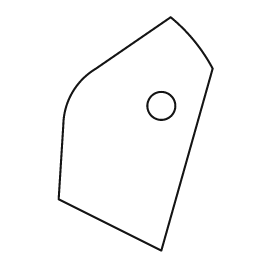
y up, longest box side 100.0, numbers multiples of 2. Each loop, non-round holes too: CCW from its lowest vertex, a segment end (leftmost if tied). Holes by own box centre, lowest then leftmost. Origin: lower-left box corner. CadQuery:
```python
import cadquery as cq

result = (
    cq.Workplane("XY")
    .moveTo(44.0, 0.0)
    .lineTo(66.0, 78.0)
    .threePointArc((58.0, 90.0), (48.0, 100.0))
    .lineTo(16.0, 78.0)
    .threePointArc((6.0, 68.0), (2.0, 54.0))
    .lineTo(0.0, 22.0)
    .close()
    .moveTo(44.0, 62.0)
    .circle(6.0)
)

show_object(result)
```